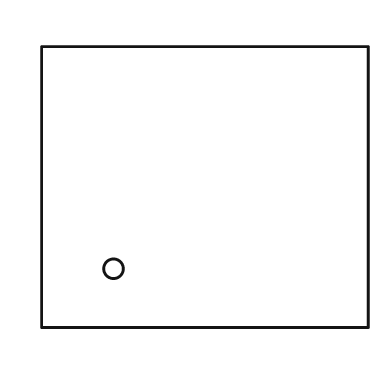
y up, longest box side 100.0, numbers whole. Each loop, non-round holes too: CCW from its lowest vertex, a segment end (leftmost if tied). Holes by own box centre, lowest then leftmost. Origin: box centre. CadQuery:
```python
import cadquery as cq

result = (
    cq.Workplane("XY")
    .moveTo(-50.0, -43.0)
    .lineTo(50.0, -43.0)
    .lineTo(50.0, 43.0)
    .lineTo(-50.0, 43.0)
    .close()
    .moveTo(-28.0, -25.0)
    .circle(3.0)
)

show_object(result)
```